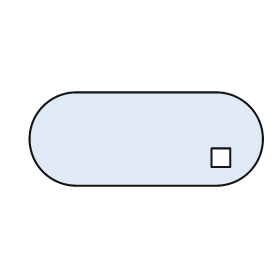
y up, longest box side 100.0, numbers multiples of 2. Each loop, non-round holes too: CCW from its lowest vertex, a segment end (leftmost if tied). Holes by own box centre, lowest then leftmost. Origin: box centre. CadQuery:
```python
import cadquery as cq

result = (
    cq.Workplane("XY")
    .moveTo(-30.0, -20.0)
    .lineTo(30.0, -20.0)
    .threePointArc((50.0, 0.0), (30.0, 20.0))
    .lineTo(-30.0, 20.0)
    .threePointArc((-50.0, 0.0), (-30.0, -20.0))
    .close()
    .moveTo(28.0, -12.0)
    .lineTo(36.0, -12.0)
    .lineTo(36.0, -4.0)
    .lineTo(28.0, -4.0)
    .close()
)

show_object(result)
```